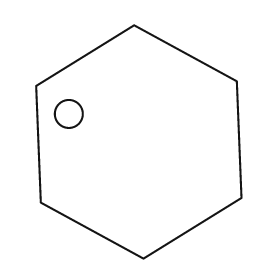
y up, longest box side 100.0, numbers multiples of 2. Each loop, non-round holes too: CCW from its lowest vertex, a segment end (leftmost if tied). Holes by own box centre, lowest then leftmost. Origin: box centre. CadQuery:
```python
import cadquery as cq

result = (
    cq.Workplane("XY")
    .moveTo(2.0, -50.0)
    .lineTo(44.0, -24.0)
    .lineTo(42.0, 26.0)
    .lineTo(-2.0, 50.0)
    .lineTo(-44.0, 24.0)
    .lineTo(-42.0, -26.0)
    .close()
    .moveTo(-30.0, 12.0)
    .circle(6.0)
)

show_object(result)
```